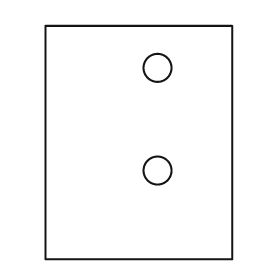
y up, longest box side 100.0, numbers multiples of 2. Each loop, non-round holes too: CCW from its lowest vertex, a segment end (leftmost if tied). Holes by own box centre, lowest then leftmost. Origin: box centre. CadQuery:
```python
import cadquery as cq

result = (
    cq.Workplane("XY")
    .moveTo(-40.0, -50.0)
    .lineTo(40.0, -50.0)
    .lineTo(40.0, 50.0)
    .lineTo(-40.0, 50.0)
    .close()
    .moveTo(8.0, -12.0)
    .circle(6.0)
    .moveTo(8.0, 32.0)
    .circle(6.0)
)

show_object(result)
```